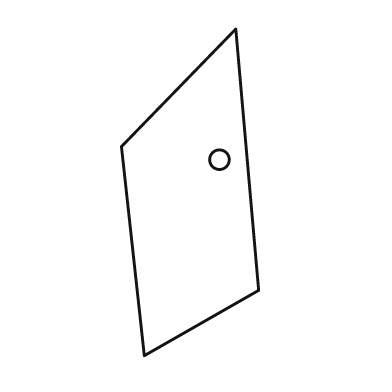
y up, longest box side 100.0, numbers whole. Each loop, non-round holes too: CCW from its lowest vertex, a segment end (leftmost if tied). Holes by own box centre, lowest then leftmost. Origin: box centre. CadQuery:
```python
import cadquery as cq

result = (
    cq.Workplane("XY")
    .moveTo(-14.0, -50.0)
    .lineTo(21.0, -30.0)
    .lineTo(14.0, 50.0)
    .lineTo(-21.0, 14.0)
    .close()
    .moveTo(9.0, 10.0)
    .circle(3.0)
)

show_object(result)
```